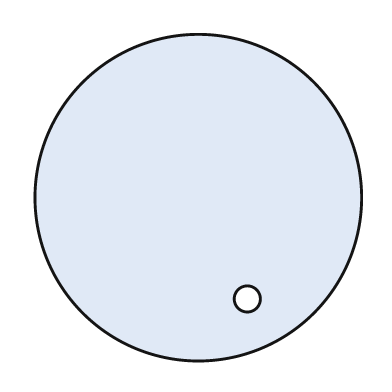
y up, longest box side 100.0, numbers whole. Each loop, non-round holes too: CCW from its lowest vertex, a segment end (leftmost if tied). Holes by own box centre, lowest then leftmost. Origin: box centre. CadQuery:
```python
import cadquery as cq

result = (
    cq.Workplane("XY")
    .moveTo(0.0, 0.0)
    .circle(50.0)
    .moveTo(15.0, -31.0)
    .circle(4.0)
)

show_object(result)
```